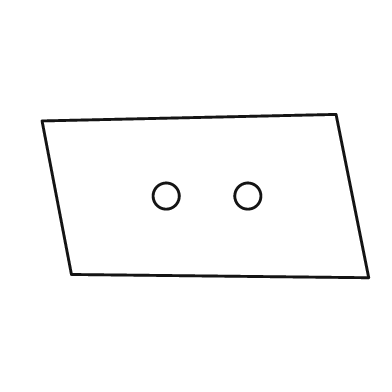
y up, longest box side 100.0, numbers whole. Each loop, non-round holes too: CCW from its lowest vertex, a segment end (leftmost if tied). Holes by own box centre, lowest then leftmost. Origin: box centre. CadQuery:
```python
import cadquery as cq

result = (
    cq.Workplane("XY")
    .moveTo(50.0, -25.0)
    .lineTo(40.0, 25.0)
    .lineTo(-50.0, 23.0)
    .lineTo(-41.0, -24.0)
    .close()
    .moveTo(-12.0, 0.0)
    .circle(4.0)
    .moveTo(13.0, 0.0)
    .circle(4.0)
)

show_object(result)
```